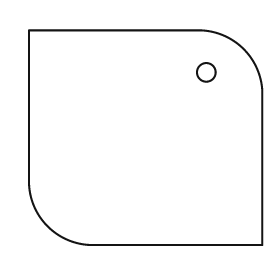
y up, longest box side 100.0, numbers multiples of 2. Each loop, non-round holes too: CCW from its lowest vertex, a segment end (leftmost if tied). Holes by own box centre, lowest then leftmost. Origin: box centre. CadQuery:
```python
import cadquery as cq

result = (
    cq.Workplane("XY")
    .moveTo(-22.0, -46.0)
    .lineTo(50.0, -46.0)
    .lineTo(50.0, 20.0)
    .threePointArc((42.0, 38.0), (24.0, 46.0))
    .lineTo(-50.0, 46.0)
    .lineTo(-50.0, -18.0)
    .threePointArc((-42.0, -38.0), (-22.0, -46.0))
    .close()
    .moveTo(26.0, 28.0)
    .circle(4.0)
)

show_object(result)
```